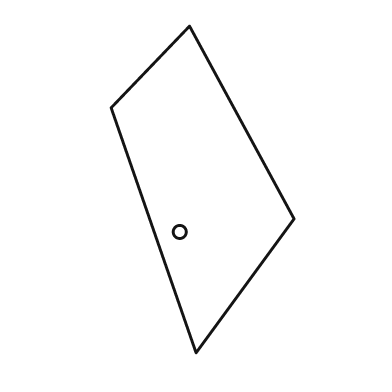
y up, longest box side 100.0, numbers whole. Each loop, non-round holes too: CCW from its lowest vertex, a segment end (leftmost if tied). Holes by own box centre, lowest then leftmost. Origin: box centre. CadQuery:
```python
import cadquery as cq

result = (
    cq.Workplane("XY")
    .moveTo(-2.0, -50.0)
    .lineTo(28.0, -9.0)
    .lineTo(-4.0, 50.0)
    .lineTo(-28.0, 25.0)
    .close()
    .moveTo(-7.0, -13.0)
    .circle(2.0)
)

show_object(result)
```